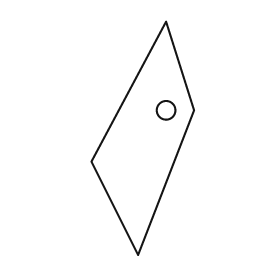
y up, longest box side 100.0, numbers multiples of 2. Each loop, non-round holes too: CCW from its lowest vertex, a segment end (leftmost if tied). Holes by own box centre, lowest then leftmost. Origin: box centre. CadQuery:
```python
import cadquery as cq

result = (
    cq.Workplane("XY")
    .moveTo(-2.0, -50.0)
    .lineTo(22.0, 12.0)
    .lineTo(10.0, 50.0)
    .lineTo(-22.0, -10.0)
    .close()
    .moveTo(10.0, 12.0)
    .circle(4.0)
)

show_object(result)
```